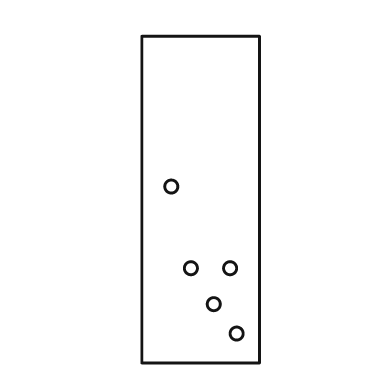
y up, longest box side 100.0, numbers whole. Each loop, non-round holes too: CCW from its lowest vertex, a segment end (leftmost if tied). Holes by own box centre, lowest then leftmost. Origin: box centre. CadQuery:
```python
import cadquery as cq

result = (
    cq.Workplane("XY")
    .moveTo(-18.0, -50.0)
    .lineTo(18.0, -50.0)
    .lineTo(18.0, 50.0)
    .lineTo(-18.0, 50.0)
    .close()
    .moveTo(11.0, -41.0)
    .circle(2.0)
    .moveTo(4.0, -32.0)
    .circle(2.0)
    .moveTo(-3.0, -21.0)
    .circle(2.0)
    .moveTo(9.0, -21.0)
    .circle(2.0)
    .moveTo(-9.0, 4.0)
    .circle(2.0)
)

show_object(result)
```